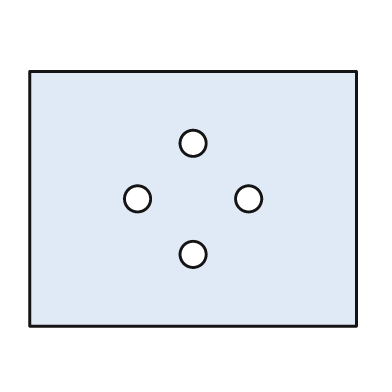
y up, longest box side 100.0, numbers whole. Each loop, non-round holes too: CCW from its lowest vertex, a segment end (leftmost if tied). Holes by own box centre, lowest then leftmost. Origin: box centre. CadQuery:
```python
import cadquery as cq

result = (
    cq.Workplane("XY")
    .moveTo(-50.0, -39.0)
    .lineTo(50.0, -39.0)
    .lineTo(50.0, 39.0)
    .lineTo(-50.0, 39.0)
    .close()
    .moveTo(0.0, -17.0)
    .circle(4.0)
    .moveTo(-17.0, 0.0)
    .circle(4.0)
    .moveTo(17.0, 0.0)
    .circle(4.0)
    .moveTo(0.0, 17.0)
    .circle(4.0)
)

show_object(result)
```